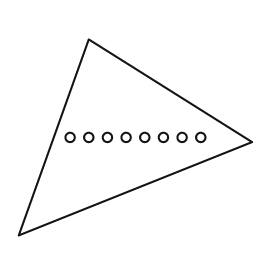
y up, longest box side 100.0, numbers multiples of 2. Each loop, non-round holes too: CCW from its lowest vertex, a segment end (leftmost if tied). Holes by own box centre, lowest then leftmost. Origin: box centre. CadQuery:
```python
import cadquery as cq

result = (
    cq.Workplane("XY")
    .moveTo(-50.0, -42.0)
    .lineTo(50.0, -2.0)
    .lineTo(-20.0, 42.0)
    .close()
    .moveTo(-28.0, 0.0)
    .circle(2.0)
    .moveTo(-20.0, 0.0)
    .circle(2.0)
    .moveTo(-12.0, 0.0)
    .circle(2.0)
    .moveTo(-4.0, 0.0)
    .circle(2.0)
    .moveTo(4.0, 0.0)
    .circle(2.0)
    .moveTo(12.0, 0.0)
    .circle(2.0)
    .moveTo(20.0, 0.0)
    .circle(2.0)
    .moveTo(28.0, 0.0)
    .circle(2.0)
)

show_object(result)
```